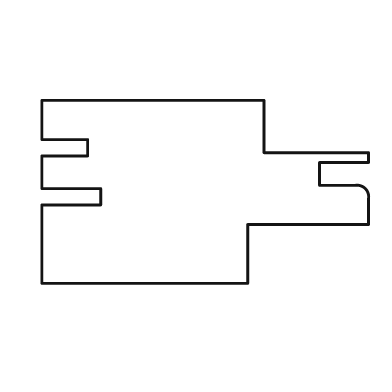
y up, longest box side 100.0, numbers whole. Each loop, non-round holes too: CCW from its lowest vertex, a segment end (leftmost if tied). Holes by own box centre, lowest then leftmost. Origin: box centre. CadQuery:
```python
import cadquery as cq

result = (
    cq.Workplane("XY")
    .moveTo(-50.0, -28.0)
    .lineTo(13.0, -28.0)
    .lineTo(13.0, -10.0)
    .lineTo(50.0, -10.0)
    .lineTo(50.0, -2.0)
    .threePointArc((49.0, 1.0), (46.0, 2.0))
    .lineTo(35.0, 2.0)
    .lineTo(35.0, 9.0)
    .lineTo(50.0, 9.0)
    .lineTo(50.0, 12.0)
    .lineTo(18.0, 12.0)
    .lineTo(18.0, 28.0)
    .lineTo(-50.0, 28.0)
    .lineTo(-50.0, 16.0)
    .lineTo(-36.0, 16.0)
    .lineTo(-36.0, 11.0)
    .lineTo(-50.0, 11.0)
    .lineTo(-50.0, 1.0)
    .lineTo(-32.0, 1.0)
    .lineTo(-32.0, -4.0)
    .lineTo(-50.0, -4.0)
    .close()
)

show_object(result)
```